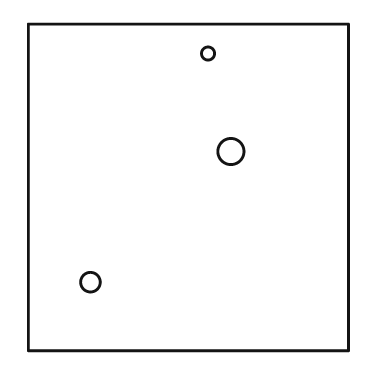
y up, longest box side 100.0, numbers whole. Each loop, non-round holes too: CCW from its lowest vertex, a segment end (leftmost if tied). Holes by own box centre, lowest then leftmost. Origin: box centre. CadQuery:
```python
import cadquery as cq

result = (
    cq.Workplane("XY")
    .moveTo(-49.0, -50.0)
    .lineTo(49.0, -50.0)
    .lineTo(49.0, 50.0)
    .lineTo(-49.0, 50.0)
    .close()
    .moveTo(-30.0, -29.0)
    .circle(3.0)
    .moveTo(13.0, 11.0)
    .circle(4.0)
    .moveTo(6.0, 41.0)
    .circle(2.0)
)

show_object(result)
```